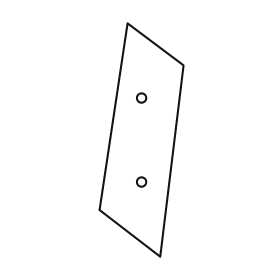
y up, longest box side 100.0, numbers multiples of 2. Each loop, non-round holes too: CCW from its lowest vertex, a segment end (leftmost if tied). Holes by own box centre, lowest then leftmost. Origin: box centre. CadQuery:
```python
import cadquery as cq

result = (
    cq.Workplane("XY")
    .moveTo(8.0, -50.0)
    .lineTo(18.0, 32.0)
    .lineTo(-6.0, 50.0)
    .lineTo(-18.0, -30.0)
    .close()
    .moveTo(0.0, -18.0)
    .circle(2.0)
    .moveTo(0.0, 18.0)
    .circle(2.0)
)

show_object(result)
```